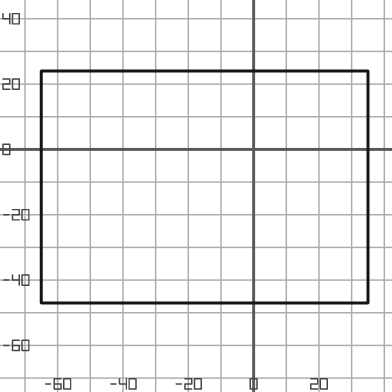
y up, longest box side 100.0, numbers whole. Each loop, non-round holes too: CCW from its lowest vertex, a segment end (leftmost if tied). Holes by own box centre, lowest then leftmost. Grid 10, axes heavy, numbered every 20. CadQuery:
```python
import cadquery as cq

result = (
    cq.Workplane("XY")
    .moveTo(-65.0, -47.0)
    .lineTo(35.0, -47.0)
    .lineTo(35.0, 24.0)
    .lineTo(-65.0, 24.0)
    .close()
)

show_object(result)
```